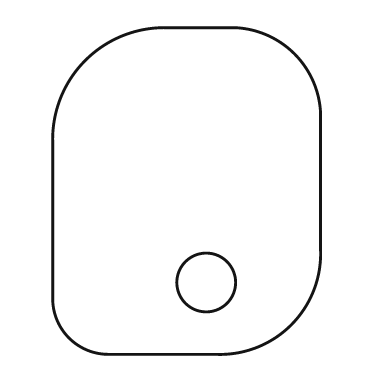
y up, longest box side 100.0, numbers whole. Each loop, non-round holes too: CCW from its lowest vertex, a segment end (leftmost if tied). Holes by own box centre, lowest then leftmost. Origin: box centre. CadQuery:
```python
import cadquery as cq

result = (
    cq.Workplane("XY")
    .moveTo(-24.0, -50.0)
    .lineTo(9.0, -50.0)
    .threePointArc((32.0, -41.0), (41.0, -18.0))
    .lineTo(41.0, 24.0)
    .threePointArc((33.0, 42.0), (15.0, 50.0))
    .lineTo(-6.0, 50.0)
    .threePointArc((-31.0, 40.0), (-41.0, 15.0))
    .lineTo(-41.0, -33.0)
    .threePointArc((-36.0, -45.0), (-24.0, -50.0))
    .close()
    .moveTo(6.0, -28.0)
    .circle(9.0)
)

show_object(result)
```